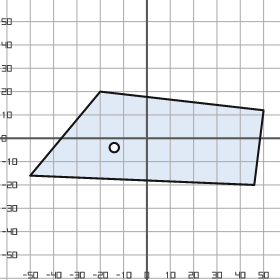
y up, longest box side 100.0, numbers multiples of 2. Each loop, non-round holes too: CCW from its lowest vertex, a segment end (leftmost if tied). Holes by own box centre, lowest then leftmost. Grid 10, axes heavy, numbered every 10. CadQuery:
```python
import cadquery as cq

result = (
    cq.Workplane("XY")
    .moveTo(46.0, -20.0)
    .lineTo(50.0, 12.0)
    .lineTo(-20.0, 20.0)
    .lineTo(-50.0, -16.0)
    .close()
    .moveTo(-14.0, -4.0)
    .circle(2.0)
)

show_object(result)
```